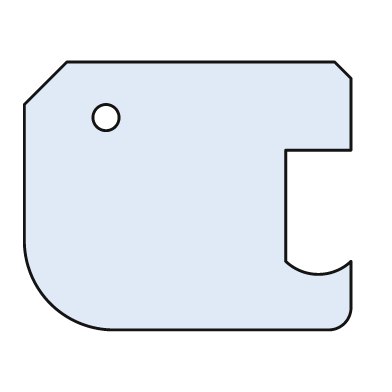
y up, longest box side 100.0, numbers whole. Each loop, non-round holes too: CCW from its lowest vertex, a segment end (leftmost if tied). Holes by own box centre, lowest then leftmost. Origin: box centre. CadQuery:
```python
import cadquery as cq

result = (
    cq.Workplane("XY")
    .moveTo(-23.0, -41.0)
    .lineTo(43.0, -41.0)
    .threePointArc((48.0, -39.0), (50.0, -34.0))
    .lineTo(50.0, -20.0)
    .threePointArc((40.0, -24.0), (30.0, -20.0))
    .lineTo(30.0, 14.0)
    .lineTo(50.0, 14.0)
    .lineTo(50.0, 36.0)
    .lineTo(45.0, 41.0)
    .lineTo(-37.0, 41.0)
    .lineTo(-50.0, 28.0)
    .lineTo(-50.0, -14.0)
    .threePointArc((-42.0, -33.0), (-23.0, -41.0))
    .close()
    .moveTo(-25.0, 24.0)
    .circle(4.0)
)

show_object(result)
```